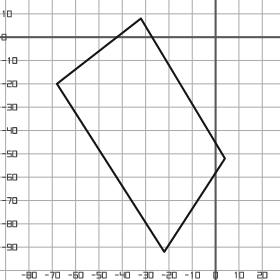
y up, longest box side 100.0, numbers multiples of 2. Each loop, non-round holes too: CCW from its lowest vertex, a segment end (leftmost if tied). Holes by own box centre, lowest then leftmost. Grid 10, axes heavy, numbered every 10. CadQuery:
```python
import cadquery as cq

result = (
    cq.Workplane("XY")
    .moveTo(-22.0, -92.0)
    .lineTo(4.0, -52.0)
    .lineTo(-32.0, 8.0)
    .lineTo(-68.0, -20.0)
    .close()
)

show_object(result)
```